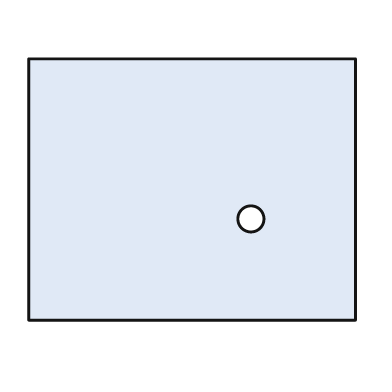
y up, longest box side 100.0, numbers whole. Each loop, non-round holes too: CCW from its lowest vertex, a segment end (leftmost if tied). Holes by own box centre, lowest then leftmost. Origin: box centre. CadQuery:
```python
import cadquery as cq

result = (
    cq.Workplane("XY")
    .moveTo(-50.0, -40.0)
    .lineTo(50.0, -40.0)
    .lineTo(50.0, 40.0)
    .lineTo(-50.0, 40.0)
    .close()
    .moveTo(18.0, -9.0)
    .circle(4.0)
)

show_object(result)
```